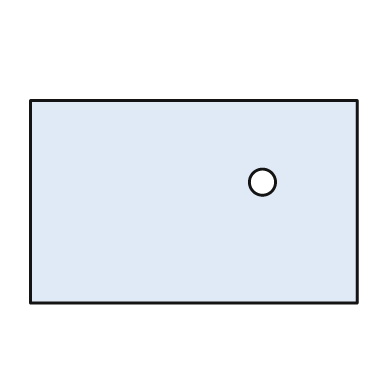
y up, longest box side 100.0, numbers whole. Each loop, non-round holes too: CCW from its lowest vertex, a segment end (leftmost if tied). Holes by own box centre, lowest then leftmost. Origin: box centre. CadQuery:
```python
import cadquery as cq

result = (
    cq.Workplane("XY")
    .moveTo(-50.0, -31.0)
    .lineTo(50.0, -31.0)
    .lineTo(50.0, 31.0)
    .lineTo(-50.0, 31.0)
    .close()
    .moveTo(21.0, 6.0)
    .circle(4.0)
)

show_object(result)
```